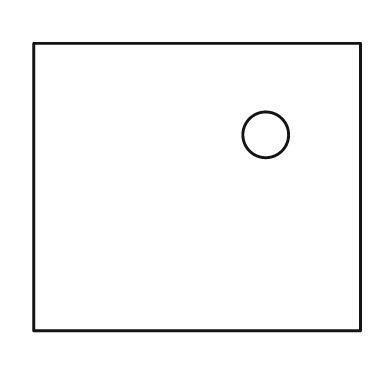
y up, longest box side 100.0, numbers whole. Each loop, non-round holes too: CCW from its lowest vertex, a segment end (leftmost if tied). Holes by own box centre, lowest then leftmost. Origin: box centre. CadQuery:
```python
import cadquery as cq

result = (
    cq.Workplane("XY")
    .moveTo(-50.0, -44.0)
    .lineTo(50.0, -44.0)
    .lineTo(50.0, 44.0)
    .lineTo(-50.0, 44.0)
    .close()
    .moveTo(21.0, 16.0)
    .circle(7.0)
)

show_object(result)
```